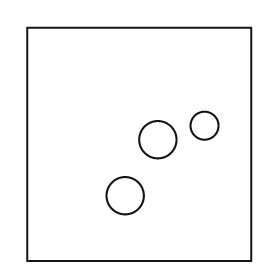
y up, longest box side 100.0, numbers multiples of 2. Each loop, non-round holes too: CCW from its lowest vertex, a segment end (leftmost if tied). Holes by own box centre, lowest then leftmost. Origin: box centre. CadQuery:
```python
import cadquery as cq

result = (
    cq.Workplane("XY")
    .moveTo(-48.0, -50.0)
    .lineTo(48.0, -50.0)
    .lineTo(48.0, 50.0)
    .lineTo(-48.0, 50.0)
    .close()
    .moveTo(-6.0, -22.0)
    .circle(8.0)
    .moveTo(8.0, 2.0)
    .circle(8.0)
    .moveTo(28.0, 8.0)
    .circle(6.0)
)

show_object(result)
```